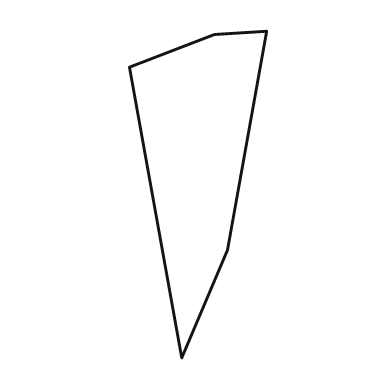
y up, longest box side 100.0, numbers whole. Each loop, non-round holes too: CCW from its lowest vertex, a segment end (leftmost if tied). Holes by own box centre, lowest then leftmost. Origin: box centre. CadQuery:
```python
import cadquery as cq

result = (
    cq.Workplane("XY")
    .moveTo(-5.0, -50.0)
    .lineTo(9.0, -17.0)
    .lineTo(21.0, 50.0)
    .lineTo(5.0, 49.0)
    .lineTo(-21.0, 39.0)
    .close()
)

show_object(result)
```